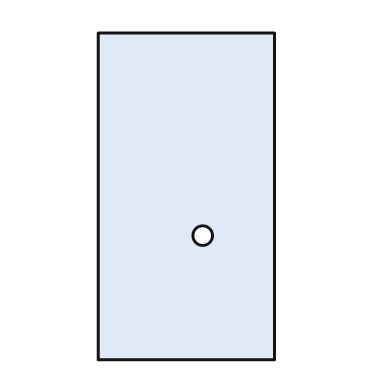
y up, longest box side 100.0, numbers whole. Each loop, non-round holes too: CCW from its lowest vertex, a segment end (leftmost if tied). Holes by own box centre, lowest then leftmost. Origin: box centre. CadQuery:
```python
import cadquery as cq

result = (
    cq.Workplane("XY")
    .moveTo(-27.0, -50.0)
    .lineTo(27.0, -50.0)
    .lineTo(27.0, 50.0)
    .lineTo(-27.0, 50.0)
    .close()
    .moveTo(5.0, -12.0)
    .circle(3.0)
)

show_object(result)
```